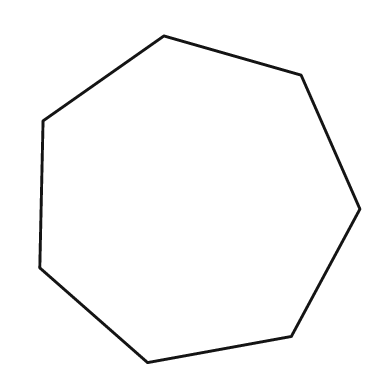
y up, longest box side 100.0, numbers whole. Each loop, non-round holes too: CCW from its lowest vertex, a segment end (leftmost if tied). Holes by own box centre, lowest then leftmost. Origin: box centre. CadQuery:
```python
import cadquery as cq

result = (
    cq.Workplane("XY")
    .moveTo(-16.0, -50.0)
    .lineTo(28.0, -42.0)
    .lineTo(49.0, -3.0)
    .lineTo(31.0, 38.0)
    .lineTo(-11.0, 50.0)
    .lineTo(-48.0, 24.0)
    .lineTo(-49.0, -21.0)
    .close()
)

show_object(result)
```